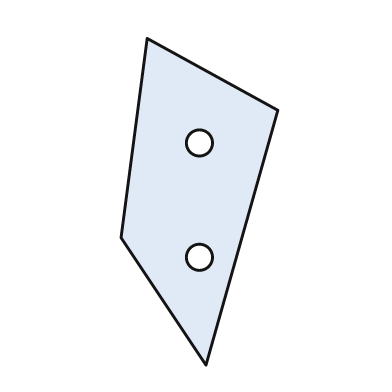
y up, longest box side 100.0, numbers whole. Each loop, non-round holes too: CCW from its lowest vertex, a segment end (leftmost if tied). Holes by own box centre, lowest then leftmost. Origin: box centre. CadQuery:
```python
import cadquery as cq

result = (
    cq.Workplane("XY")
    .moveTo(2.0, -50.0)
    .lineTo(24.0, 28.0)
    .lineTo(-16.0, 50.0)
    .lineTo(-24.0, -11.0)
    .close()
    .moveTo(0.0, -17.0)
    .circle(4.0)
    .moveTo(0.0, 18.0)
    .circle(4.0)
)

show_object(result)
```